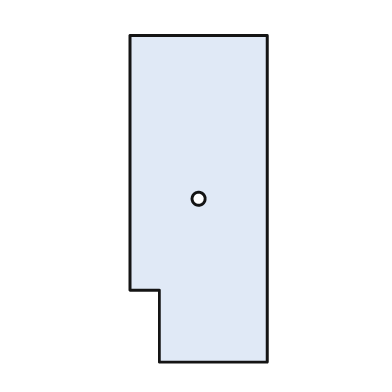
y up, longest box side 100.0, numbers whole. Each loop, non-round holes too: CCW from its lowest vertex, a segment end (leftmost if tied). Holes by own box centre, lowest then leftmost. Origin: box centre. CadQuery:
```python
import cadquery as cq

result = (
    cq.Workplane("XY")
    .moveTo(-12.0, -50.0)
    .lineTo(21.0, -50.0)
    .lineTo(21.0, 50.0)
    .lineTo(-21.0, 50.0)
    .lineTo(-21.0, -28.0)
    .lineTo(-12.0, -28.0)
    .close()
    .moveTo(0.0, 0.0)
    .circle(2.0)
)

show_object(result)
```